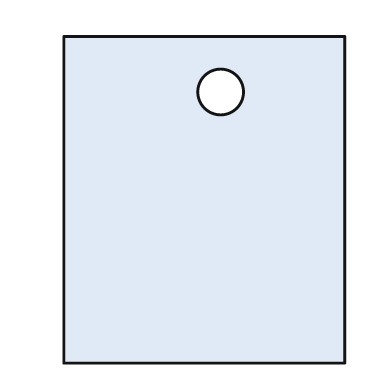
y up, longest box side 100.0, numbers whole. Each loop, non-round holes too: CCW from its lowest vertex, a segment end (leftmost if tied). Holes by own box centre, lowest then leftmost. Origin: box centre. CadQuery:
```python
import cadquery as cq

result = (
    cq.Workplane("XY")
    .moveTo(-43.0, -50.0)
    .lineTo(43.0, -50.0)
    .lineTo(43.0, 50.0)
    .lineTo(-43.0, 50.0)
    .close()
    .moveTo(5.0, 33.0)
    .circle(7.0)
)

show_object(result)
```